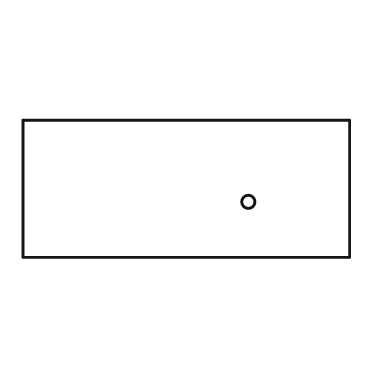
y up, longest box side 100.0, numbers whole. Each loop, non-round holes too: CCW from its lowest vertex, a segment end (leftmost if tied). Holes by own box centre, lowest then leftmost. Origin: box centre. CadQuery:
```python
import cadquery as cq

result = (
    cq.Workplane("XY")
    .moveTo(-50.0, -21.0)
    .lineTo(50.0, -21.0)
    .lineTo(50.0, 21.0)
    .lineTo(-50.0, 21.0)
    .close()
    .moveTo(19.0, -4.0)
    .circle(2.0)
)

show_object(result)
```